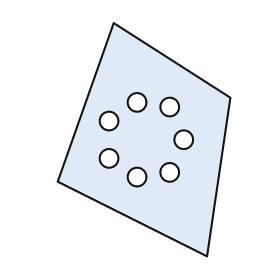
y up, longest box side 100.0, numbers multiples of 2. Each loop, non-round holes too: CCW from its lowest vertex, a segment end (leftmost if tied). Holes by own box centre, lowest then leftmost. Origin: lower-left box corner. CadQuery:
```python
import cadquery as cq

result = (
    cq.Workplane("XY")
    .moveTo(64.0, 0.0)
    .lineTo(74.0, 68.0)
    .lineTo(24.0, 100.0)
    .lineTo(0.0, 32.0)
    .close()
    .moveTo(34.0, 34.0)
    .circle(4.0)
    .moveTo(48.0, 36.0)
    .circle(4.0)
    .moveTo(22.0, 42.0)
    .circle(4.0)
    .moveTo(54.0, 50.0)
    .circle(4.0)
    .moveTo(22.0, 58.0)
    .circle(4.0)
    .moveTo(48.0, 64.0)
    .circle(4.0)
    .moveTo(34.0, 66.0)
    .circle(4.0)
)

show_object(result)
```